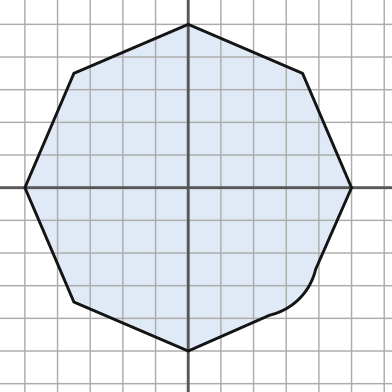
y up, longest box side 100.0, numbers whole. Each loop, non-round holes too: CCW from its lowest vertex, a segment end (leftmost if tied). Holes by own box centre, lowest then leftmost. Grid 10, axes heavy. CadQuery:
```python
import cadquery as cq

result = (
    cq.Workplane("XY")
    .moveTo(0.0, -50.0)
    .lineTo(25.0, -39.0)
    .threePointArc((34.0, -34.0), (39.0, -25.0))
    .lineTo(50.0, 0.0)
    .lineTo(35.0, 35.0)
    .lineTo(0.0, 50.0)
    .lineTo(-35.0, 35.0)
    .lineTo(-50.0, 0.0)
    .lineTo(-35.0, -35.0)
    .close()
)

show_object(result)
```